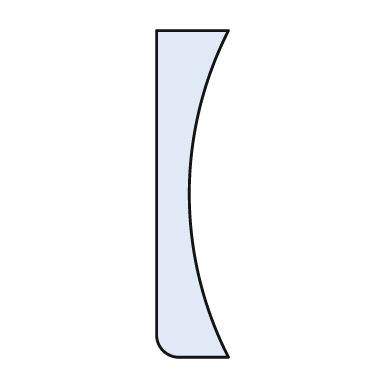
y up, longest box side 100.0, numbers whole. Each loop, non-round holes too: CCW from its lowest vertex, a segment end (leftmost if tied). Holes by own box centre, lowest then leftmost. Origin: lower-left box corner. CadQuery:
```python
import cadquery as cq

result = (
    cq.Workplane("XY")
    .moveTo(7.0, 0.0)
    .lineTo(22.0, 0.0)
    .threePointArc((10.0, 50.0), (22.0, 100.0))
    .lineTo(0.0, 100.0)
    .lineTo(0.0, 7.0)
    .threePointArc((2.0, 2.0), (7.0, 0.0))
    .close()
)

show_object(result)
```